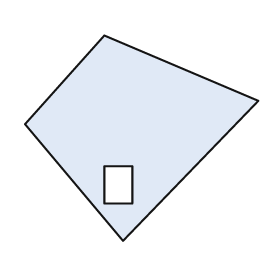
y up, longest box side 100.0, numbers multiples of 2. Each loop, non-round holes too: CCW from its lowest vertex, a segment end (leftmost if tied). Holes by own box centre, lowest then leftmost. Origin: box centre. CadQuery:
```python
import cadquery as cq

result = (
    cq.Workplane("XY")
    .moveTo(-8.0, -44.0)
    .lineTo(50.0, 16.0)
    .lineTo(-16.0, 44.0)
    .lineTo(-50.0, 6.0)
    .close()
    .moveTo(-16.0, -28.0)
    .lineTo(-4.0, -28.0)
    .lineTo(-4.0, -12.0)
    .lineTo(-16.0, -12.0)
    .close()
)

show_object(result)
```